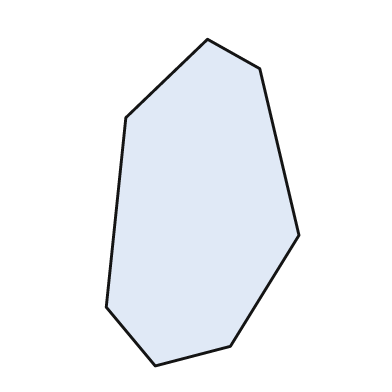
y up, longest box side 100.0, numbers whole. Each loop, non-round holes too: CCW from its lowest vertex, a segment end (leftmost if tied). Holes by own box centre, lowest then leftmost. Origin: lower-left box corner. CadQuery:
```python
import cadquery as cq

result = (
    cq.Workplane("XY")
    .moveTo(15.0, 0.0)
    .lineTo(38.0, 6.0)
    .lineTo(59.0, 40.0)
    .lineTo(47.0, 91.0)
    .lineTo(31.0, 100.0)
    .lineTo(6.0, 76.0)
    .lineTo(0.0, 18.0)
    .close()
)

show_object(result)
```